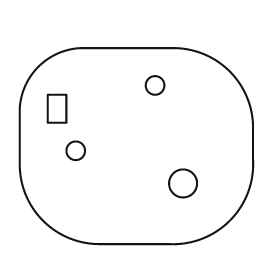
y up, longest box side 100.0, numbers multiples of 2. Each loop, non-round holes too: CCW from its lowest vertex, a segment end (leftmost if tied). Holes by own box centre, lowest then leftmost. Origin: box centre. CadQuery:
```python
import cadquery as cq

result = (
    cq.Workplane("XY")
    .moveTo(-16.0, -42.0)
    .lineTo(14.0, -42.0)
    .threePointArc((40.0, -32.0), (50.0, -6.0))
    .lineTo(50.0, 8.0)
    .threePointArc((40.0, 32.0), (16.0, 42.0))
    .lineTo(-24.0, 42.0)
    .threePointArc((-42.0, 34.0), (-50.0, 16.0))
    .lineTo(-50.0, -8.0)
    .threePointArc((-40.0, -32.0), (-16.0, -42.0))
    .close()
    .moveTo(20.0, -16.0)
    .circle(6.0)
    .moveTo(-26.0, -2.0)
    .circle(4.0)
    .moveTo(-38.0, 10.0)
    .lineTo(-30.0, 10.0)
    .lineTo(-30.0, 22.0)
    .lineTo(-38.0, 22.0)
    .close()
    .moveTo(8.0, 26.0)
    .circle(4.0)
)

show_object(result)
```